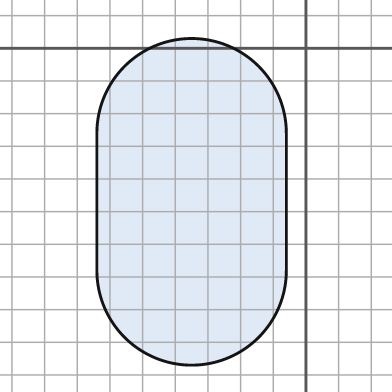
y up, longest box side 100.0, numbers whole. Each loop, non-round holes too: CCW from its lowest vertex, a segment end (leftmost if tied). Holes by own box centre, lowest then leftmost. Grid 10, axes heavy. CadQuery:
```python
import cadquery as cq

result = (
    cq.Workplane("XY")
    .moveTo(-64.0, -68.0)
    .threePointArc((-35.0, -97.0), (-6.0, -68.0))
    .lineTo(-6.0, -26.0)
    .threePointArc((-35.0, 3.0), (-64.0, -26.0))
    .close()
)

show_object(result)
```